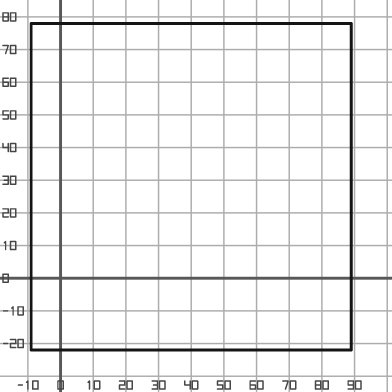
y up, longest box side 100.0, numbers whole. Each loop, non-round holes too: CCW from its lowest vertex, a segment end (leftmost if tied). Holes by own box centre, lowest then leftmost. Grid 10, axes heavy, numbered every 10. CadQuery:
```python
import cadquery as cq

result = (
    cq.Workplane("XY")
    .moveTo(-9.0, -22.0)
    .lineTo(89.0, -22.0)
    .lineTo(89.0, 78.0)
    .lineTo(-9.0, 78.0)
    .close()
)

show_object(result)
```